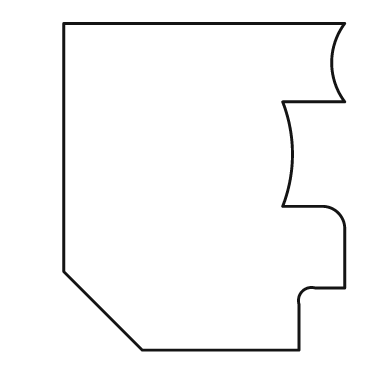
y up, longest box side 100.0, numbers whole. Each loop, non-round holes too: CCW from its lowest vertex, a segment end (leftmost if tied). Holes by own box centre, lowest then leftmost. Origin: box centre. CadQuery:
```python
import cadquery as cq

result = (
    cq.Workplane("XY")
    .moveTo(-19.0, -50.0)
    .lineTo(29.0, -50.0)
    .lineTo(29.0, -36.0)
    .threePointArc((30.0, -32.0), (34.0, -31.0))
    .lineTo(43.0, -31.0)
    .lineTo(43.0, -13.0)
    .threePointArc((41.0, -8.0), (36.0, -6.0))
    .lineTo(24.0, -6.0)
    .threePointArc((27.0, 10.0), (24.0, 26.0))
    .lineTo(43.0, 26.0)
    .threePointArc((39.0, 38.0), (43.0, 50.0))
    .lineTo(-43.0, 50.0)
    .lineTo(-43.0, -26.0)
    .close()
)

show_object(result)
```